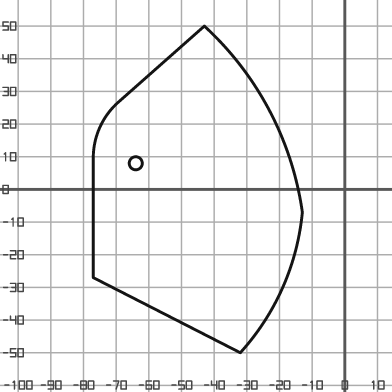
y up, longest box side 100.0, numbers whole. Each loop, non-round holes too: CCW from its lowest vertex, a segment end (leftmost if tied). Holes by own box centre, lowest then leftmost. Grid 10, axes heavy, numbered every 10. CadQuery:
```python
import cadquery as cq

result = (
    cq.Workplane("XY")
    .moveTo(-32.0, -50.0)
    .threePointArc((-19.0, -30.0), (-13.0, -7.0))
    .threePointArc((-23.0, 24.0), (-43.0, 50.0))
    .lineTo(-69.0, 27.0)
    .threePointArc((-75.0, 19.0), (-77.0, 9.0))
    .lineTo(-77.0, -27.0)
    .close()
    .moveTo(-64.0, 8.0)
    .circle(2.0)
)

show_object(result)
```